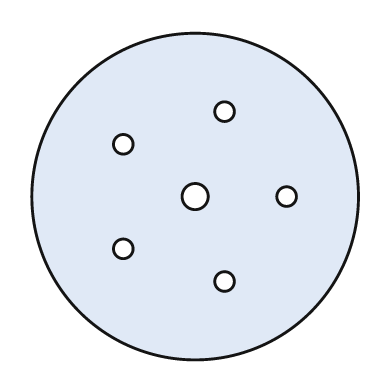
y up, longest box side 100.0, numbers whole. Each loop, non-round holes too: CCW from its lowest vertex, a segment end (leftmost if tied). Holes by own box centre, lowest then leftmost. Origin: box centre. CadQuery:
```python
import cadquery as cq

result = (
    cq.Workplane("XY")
    .moveTo(0.0, 0.0)
    .circle(50.0)
    .moveTo(9.0, -26.0)
    .circle(3.0)
    .moveTo(-22.0, -16.0)
    .circle(3.0)
    .moveTo(0.0, 0.0)
    .circle(4.0)
    .moveTo(28.0, 0.0)
    .circle(3.0)
    .moveTo(-22.0, 16.0)
    .circle(3.0)
    .moveTo(9.0, 26.0)
    .circle(3.0)
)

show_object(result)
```